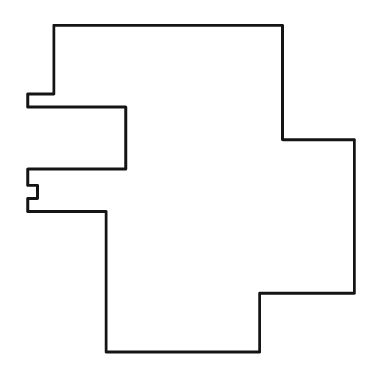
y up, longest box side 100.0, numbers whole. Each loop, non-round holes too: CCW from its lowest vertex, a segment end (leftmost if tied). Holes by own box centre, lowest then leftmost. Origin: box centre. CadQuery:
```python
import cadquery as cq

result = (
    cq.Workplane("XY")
    .moveTo(-26.0, -50.0)
    .lineTo(21.0, -50.0)
    .lineTo(21.0, -32.0)
    .lineTo(50.0, -32.0)
    .lineTo(50.0, 15.0)
    .lineTo(28.0, 15.0)
    .lineTo(28.0, 50.0)
    .lineTo(-42.0, 50.0)
    .lineTo(-42.0, 29.0)
    .lineTo(-50.0, 29.0)
    .lineTo(-50.0, 25.0)
    .lineTo(-20.0, 25.0)
    .lineTo(-20.0, 6.0)
    .lineTo(-50.0, 6.0)
    .lineTo(-50.0, 1.0)
    .lineTo(-47.0, 1.0)
    .lineTo(-47.0, -3.0)
    .lineTo(-50.0, -3.0)
    .lineTo(-50.0, -7.0)
    .lineTo(-26.0, -7.0)
    .close()
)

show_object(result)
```